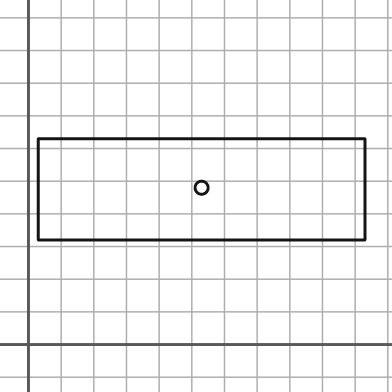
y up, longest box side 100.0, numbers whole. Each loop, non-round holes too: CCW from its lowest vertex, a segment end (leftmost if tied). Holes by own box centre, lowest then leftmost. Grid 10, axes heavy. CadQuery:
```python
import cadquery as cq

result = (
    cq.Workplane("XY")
    .moveTo(3.0, 32.0)
    .lineTo(103.0, 32.0)
    .lineTo(103.0, 63.0)
    .lineTo(3.0, 63.0)
    .close()
    .moveTo(53.0, 48.0)
    .circle(2.0)
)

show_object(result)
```